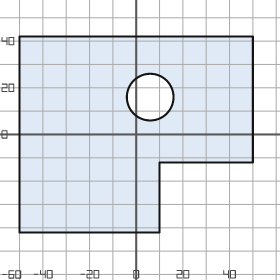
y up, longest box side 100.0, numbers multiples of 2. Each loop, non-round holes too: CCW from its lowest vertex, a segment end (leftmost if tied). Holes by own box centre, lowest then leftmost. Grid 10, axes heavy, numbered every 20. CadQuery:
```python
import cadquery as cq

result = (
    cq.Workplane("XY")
    .moveTo(-50.0, -42.0)
    .lineTo(10.0, -42.0)
    .lineTo(10.0, -12.0)
    .lineTo(50.0, -12.0)
    .lineTo(50.0, 42.0)
    .lineTo(-50.0, 42.0)
    .close()
    .moveTo(6.0, 16.0)
    .circle(10.0)
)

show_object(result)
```